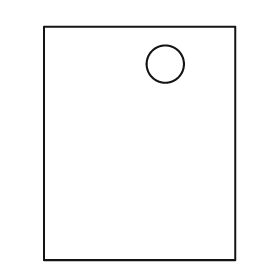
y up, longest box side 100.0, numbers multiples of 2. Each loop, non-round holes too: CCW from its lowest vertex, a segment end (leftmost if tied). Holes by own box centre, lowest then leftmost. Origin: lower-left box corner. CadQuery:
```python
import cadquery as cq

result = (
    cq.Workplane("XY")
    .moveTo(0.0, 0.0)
    .lineTo(82.0, 0.0)
    .lineTo(82.0, 100.0)
    .lineTo(0.0, 100.0)
    .close()
    .moveTo(52.0, 84.0)
    .circle(8.0)
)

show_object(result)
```